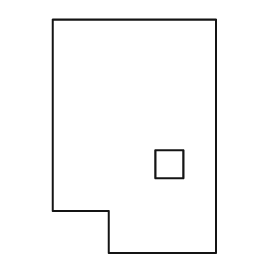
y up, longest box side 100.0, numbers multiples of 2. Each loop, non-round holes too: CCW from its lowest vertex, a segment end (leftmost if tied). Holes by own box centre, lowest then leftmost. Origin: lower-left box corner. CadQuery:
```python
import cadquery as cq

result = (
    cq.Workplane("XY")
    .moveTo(24.0, 0.0)
    .lineTo(70.0, 0.0)
    .lineTo(70.0, 100.0)
    .lineTo(0.0, 100.0)
    .lineTo(0.0, 18.0)
    .lineTo(24.0, 18.0)
    .close()
    .moveTo(44.0, 32.0)
    .lineTo(56.0, 32.0)
    .lineTo(56.0, 44.0)
    .lineTo(44.0, 44.0)
    .close()
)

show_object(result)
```